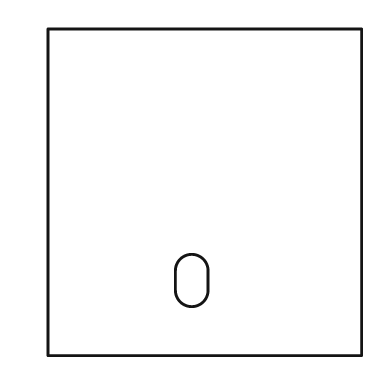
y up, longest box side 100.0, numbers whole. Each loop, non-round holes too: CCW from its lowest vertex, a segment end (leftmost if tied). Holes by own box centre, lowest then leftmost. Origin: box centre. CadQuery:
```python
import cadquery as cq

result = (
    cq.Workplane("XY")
    .moveTo(-48.0, -50.0)
    .lineTo(48.0, -50.0)
    .lineTo(48.0, 50.0)
    .lineTo(-48.0, 50.0)
    .close()
    .moveTo(-9.0, -30.0)
    .threePointArc((-4.0, -35.0), (1.0, -30.0))
    .lineTo(1.0, -24.0)
    .threePointArc((-4.0, -19.0), (-9.0, -24.0))
    .close()
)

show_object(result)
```